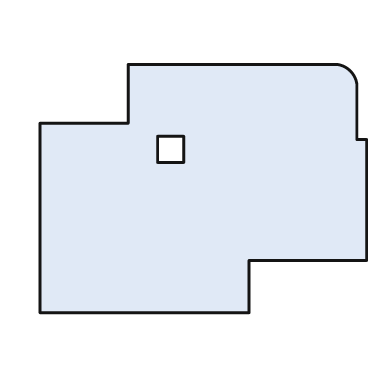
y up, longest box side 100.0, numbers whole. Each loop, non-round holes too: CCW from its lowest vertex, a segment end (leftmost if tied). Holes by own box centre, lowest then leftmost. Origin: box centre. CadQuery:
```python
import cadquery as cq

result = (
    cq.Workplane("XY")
    .moveTo(-50.0, -38.0)
    .lineTo(14.0, -38.0)
    .lineTo(14.0, -22.0)
    .lineTo(50.0, -22.0)
    .lineTo(50.0, 15.0)
    .lineTo(47.0, 15.0)
    .lineTo(47.0, 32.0)
    .threePointArc((45.0, 36.0), (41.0, 38.0))
    .lineTo(-23.0, 38.0)
    .lineTo(-23.0, 20.0)
    .lineTo(-50.0, 20.0)
    .close()
    .moveTo(-14.0, 8.0)
    .lineTo(-6.0, 8.0)
    .lineTo(-6.0, 16.0)
    .lineTo(-14.0, 16.0)
    .close()
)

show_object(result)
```